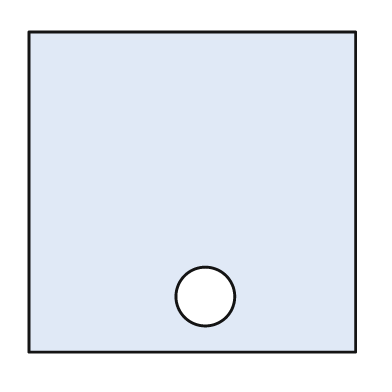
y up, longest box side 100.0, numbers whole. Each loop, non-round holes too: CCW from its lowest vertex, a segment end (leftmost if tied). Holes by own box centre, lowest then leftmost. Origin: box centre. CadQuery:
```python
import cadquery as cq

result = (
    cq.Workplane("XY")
    .moveTo(-50.0, -49.0)
    .lineTo(50.0, -49.0)
    .lineTo(50.0, 49.0)
    .lineTo(-50.0, 49.0)
    .close()
    .moveTo(4.0, -32.0)
    .circle(9.0)
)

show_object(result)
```